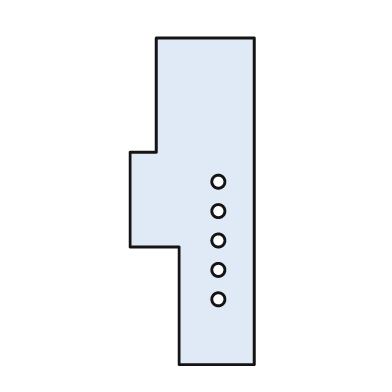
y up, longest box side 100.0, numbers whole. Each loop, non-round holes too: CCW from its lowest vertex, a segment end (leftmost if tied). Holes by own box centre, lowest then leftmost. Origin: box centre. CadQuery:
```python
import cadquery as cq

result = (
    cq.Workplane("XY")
    .moveTo(-4.0, -50.0)
    .lineTo(19.0, -50.0)
    .lineTo(19.0, 50.0)
    .lineTo(-11.0, 50.0)
    .lineTo(-11.0, 15.0)
    .lineTo(-19.0, 15.0)
    .lineTo(-19.0, -14.0)
    .lineTo(-4.0, -14.0)
    .close()
    .moveTo(8.0, -30.0)
    .circle(2.0)
    .moveTo(8.0, -21.0)
    .circle(2.0)
    .moveTo(8.0, -12.0)
    .circle(2.0)
    .moveTo(8.0, -3.0)
    .circle(2.0)
    .moveTo(8.0, 6.0)
    .circle(2.0)
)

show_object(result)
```